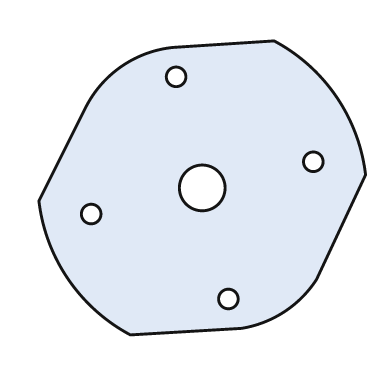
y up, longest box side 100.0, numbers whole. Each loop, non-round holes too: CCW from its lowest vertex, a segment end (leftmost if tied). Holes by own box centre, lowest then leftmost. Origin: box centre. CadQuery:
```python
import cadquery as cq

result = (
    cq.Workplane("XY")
    .moveTo(-22.0, -45.0)
    .lineTo(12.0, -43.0)
    .threePointArc((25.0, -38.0), (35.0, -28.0))
    .lineTo(50.0, 4.0)
    .threePointArc((41.0, 28.0), (22.0, 45.0))
    .lineTo(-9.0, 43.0)
    .threePointArc((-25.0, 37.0), (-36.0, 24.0))
    .lineTo(-50.0, -4.0)
    .threePointArc((-41.0, -28.0), (-22.0, -45.0))
    .close()
    .moveTo(8.0, -34.0)
    .circle(3.0)
    .moveTo(-34.0, -8.0)
    .circle(3.0)
    .moveTo(0.0, 0.0)
    .circle(7.0)
    .moveTo(34.0, 8.0)
    .circle(3.0)
    .moveTo(-8.0, 34.0)
    .circle(3.0)
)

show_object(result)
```